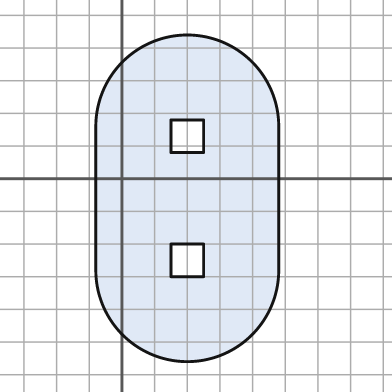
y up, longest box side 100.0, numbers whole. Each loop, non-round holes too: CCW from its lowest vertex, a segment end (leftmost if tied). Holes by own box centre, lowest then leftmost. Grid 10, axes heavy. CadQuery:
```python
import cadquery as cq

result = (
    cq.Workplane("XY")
    .moveTo(-8.0, -28.0)
    .threePointArc((20.0, -56.0), (48.0, -28.0))
    .lineTo(48.0, 16.0)
    .threePointArc((20.0, 44.0), (-8.0, 16.0))
    .close()
    .moveTo(15.0, -30.0)
    .lineTo(25.0, -30.0)
    .lineTo(25.0, -20.0)
    .lineTo(15.0, -20.0)
    .close()
    .moveTo(15.0, 8.0)
    .lineTo(25.0, 8.0)
    .lineTo(25.0, 18.0)
    .lineTo(15.0, 18.0)
    .close()
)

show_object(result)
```